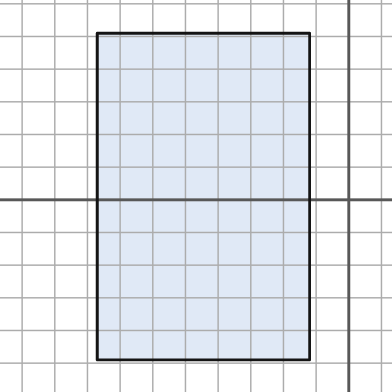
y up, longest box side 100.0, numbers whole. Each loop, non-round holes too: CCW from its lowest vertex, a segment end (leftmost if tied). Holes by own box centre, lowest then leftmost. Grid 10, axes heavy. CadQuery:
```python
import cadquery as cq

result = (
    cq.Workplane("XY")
    .moveTo(-77.0, -49.0)
    .lineTo(-12.0, -49.0)
    .lineTo(-12.0, 51.0)
    .lineTo(-77.0, 51.0)
    .close()
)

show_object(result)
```